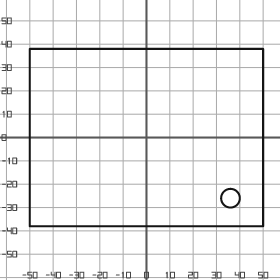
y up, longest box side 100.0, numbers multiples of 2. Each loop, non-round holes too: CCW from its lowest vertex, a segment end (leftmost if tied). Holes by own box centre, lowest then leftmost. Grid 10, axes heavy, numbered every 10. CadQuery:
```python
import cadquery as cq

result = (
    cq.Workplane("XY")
    .moveTo(-50.0, -38.0)
    .lineTo(50.0, -38.0)
    .lineTo(50.0, 38.0)
    .lineTo(-50.0, 38.0)
    .close()
    .moveTo(36.0, -26.0)
    .circle(4.0)
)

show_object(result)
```